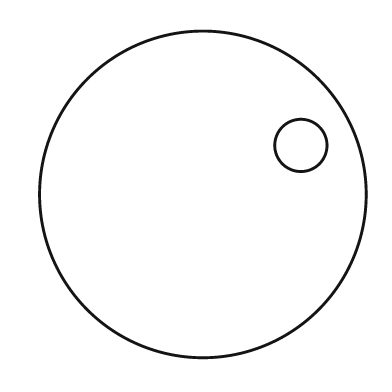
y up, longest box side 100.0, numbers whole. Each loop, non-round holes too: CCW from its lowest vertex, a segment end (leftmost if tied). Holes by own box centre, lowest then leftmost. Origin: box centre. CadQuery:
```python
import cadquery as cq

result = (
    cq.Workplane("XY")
    .moveTo(0.0, 0.0)
    .circle(50.0)
    .moveTo(30.0, 15.0)
    .circle(8.0)
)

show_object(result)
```